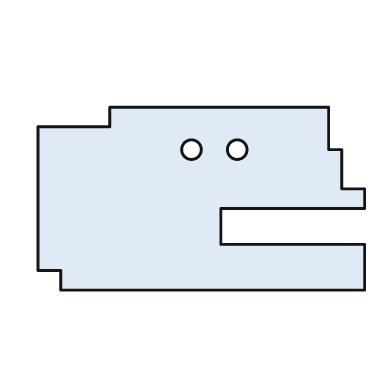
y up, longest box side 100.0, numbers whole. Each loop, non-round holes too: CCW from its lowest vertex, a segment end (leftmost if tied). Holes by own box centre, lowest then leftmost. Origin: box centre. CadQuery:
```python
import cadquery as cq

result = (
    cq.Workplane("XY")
    .moveTo(-43.0, -28.0)
    .lineTo(50.0, -28.0)
    .lineTo(50.0, -14.0)
    .lineTo(6.0, -14.0)
    .lineTo(6.0, -3.0)
    .lineTo(50.0, -3.0)
    .lineTo(50.0, 3.0)
    .lineTo(43.0, 3.0)
    .lineTo(43.0, 15.0)
    .lineTo(39.0, 15.0)
    .lineTo(39.0, 28.0)
    .lineTo(-28.0, 28.0)
    .lineTo(-28.0, 22.0)
    .lineTo(-50.0, 22.0)
    .lineTo(-50.0, -22.0)
    .lineTo(-43.0, -22.0)
    .close()
    .moveTo(-3.0, 15.0)
    .circle(3.0)
    .moveTo(11.0, 15.0)
    .circle(3.0)
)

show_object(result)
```